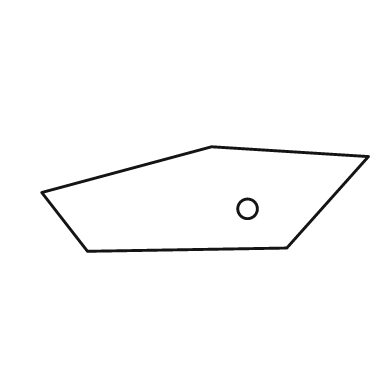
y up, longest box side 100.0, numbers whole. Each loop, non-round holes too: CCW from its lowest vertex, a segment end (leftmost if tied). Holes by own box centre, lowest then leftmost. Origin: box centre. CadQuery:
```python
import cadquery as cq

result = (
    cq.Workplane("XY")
    .moveTo(-36.0, -16.0)
    .lineTo(25.0, -15.0)
    .lineTo(50.0, 13.0)
    .lineTo(2.0, 16.0)
    .lineTo(-50.0, 2.0)
    .close()
    .moveTo(13.0, -3.0)
    .circle(3.0)
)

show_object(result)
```